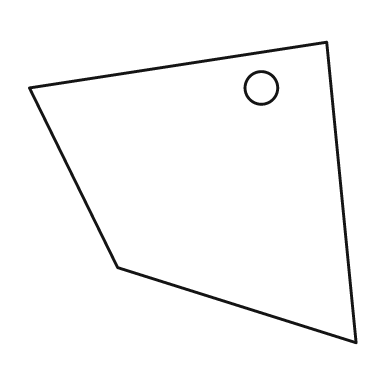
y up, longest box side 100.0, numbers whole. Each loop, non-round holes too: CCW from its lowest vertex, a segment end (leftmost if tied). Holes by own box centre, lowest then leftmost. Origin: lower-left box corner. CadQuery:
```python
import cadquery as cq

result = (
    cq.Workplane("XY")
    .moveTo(100.0, 0.0)
    .lineTo(91.0, 92.0)
    .lineTo(0.0, 78.0)
    .lineTo(27.0, 23.0)
    .close()
    .moveTo(71.0, 78.0)
    .circle(5.0)
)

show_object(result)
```